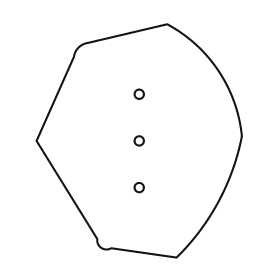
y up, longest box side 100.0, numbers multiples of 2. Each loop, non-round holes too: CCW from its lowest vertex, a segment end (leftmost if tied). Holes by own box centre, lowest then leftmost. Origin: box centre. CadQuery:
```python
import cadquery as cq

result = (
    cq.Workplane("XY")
    .moveTo(16.0, -50.0)
    .threePointArc((34.0, -26.0), (44.0, 2.0))
    .threePointArc((34.0, 30.0), (12.0, 50.0))
    .lineTo(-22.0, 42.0)
    .threePointArc((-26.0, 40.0), (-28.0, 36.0))
    .lineTo(-44.0, 0.0)
    .lineTo(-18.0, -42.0)
    .threePointArc((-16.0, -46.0), (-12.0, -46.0))
    .close()
    .moveTo(0.0, -20.0)
    .circle(2.0)
    .moveTo(0.0, 0.0)
    .circle(2.0)
    .moveTo(0.0, 20.0)
    .circle(2.0)
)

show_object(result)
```